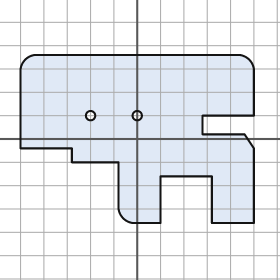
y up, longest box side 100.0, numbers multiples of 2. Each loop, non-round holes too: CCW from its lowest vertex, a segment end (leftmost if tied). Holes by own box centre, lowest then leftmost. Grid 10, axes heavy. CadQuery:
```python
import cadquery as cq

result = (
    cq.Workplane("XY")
    .moveTo(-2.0, -36.0)
    .lineTo(10.0, -36.0)
    .lineTo(10.0, -16.0)
    .lineTo(32.0, -16.0)
    .lineTo(32.0, -36.0)
    .lineTo(50.0, -36.0)
    .lineTo(50.0, -4.0)
    .lineTo(46.0, 2.0)
    .lineTo(28.0, 2.0)
    .lineTo(28.0, 10.0)
    .lineTo(50.0, 10.0)
    .lineTo(50.0, 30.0)
    .threePointArc((48.0, 34.0), (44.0, 36.0))
    .lineTo(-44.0, 36.0)
    .threePointArc((-48.0, 34.0), (-50.0, 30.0))
    .lineTo(-50.0, -4.0)
    .lineTo(-28.0, -4.0)
    .lineTo(-28.0, -10.0)
    .lineTo(-8.0, -10.0)
    .lineTo(-8.0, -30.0)
    .threePointArc((-6.0, -34.0), (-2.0, -36.0))
    .close()
    .moveTo(-20.0, 10.0)
    .circle(2.0)
    .moveTo(0.0, 10.0)
    .circle(2.0)
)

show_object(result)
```